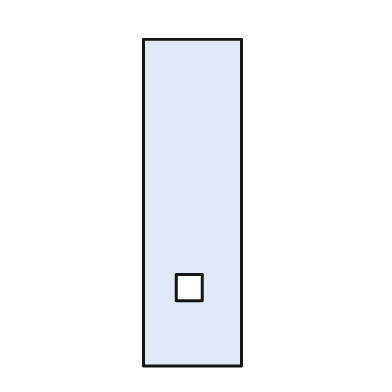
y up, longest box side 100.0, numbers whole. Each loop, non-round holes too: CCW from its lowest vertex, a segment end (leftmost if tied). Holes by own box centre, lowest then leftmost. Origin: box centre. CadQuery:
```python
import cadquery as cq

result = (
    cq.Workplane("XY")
    .moveTo(-15.0, -50.0)
    .lineTo(15.0, -50.0)
    .lineTo(15.0, 50.0)
    .lineTo(-15.0, 50.0)
    .close()
    .moveTo(-5.0, -30.0)
    .lineTo(3.0, -30.0)
    .lineTo(3.0, -22.0)
    .lineTo(-5.0, -22.0)
    .close()
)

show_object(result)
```